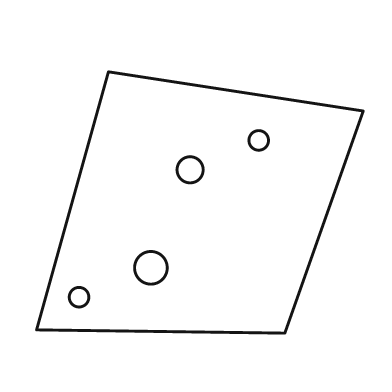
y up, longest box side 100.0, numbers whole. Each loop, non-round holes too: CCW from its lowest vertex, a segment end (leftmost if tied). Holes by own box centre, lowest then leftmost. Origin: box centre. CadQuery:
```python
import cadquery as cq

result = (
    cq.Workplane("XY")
    .moveTo(26.0, -40.0)
    .lineTo(50.0, 28.0)
    .lineTo(-28.0, 40.0)
    .lineTo(-50.0, -39.0)
    .close()
    .moveTo(-37.0, -29.0)
    .circle(3.0)
    .moveTo(-15.0, -20.0)
    .circle(5.0)
    .moveTo(-3.0, 10.0)
    .circle(4.0)
    .moveTo(18.0, 19.0)
    .circle(3.0)
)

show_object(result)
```